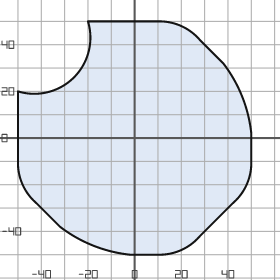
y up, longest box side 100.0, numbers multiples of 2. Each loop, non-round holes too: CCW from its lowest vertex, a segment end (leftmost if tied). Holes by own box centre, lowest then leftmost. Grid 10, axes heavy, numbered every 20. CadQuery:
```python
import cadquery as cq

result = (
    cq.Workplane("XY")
    .moveTo(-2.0, -50.0)
    .lineTo(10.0, -50.0)
    .threePointArc((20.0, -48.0), (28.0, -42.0))
    .lineTo(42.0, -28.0)
    .threePointArc((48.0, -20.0), (50.0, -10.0))
    .lineTo(50.0, 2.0)
    .threePointArc((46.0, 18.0), (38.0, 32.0))
    .lineTo(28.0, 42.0)
    .threePointArc((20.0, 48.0), (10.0, 50.0))
    .lineTo(-20.0, 50.0)
    .threePointArc((-26.0, 26.0), (-50.0, 20.0))
    .lineTo(-50.0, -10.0)
    .threePointArc((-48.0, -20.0), (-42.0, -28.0))
    .lineTo(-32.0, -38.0)
    .threePointArc((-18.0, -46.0), (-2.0, -50.0))
    .close()
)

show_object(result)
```